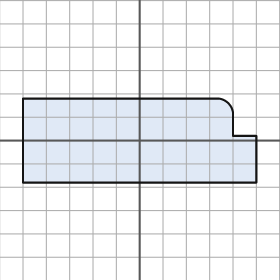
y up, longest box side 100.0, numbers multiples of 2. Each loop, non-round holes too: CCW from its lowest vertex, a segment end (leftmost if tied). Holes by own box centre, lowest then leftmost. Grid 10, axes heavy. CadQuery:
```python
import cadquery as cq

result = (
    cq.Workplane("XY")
    .moveTo(-50.0, -18.0)
    .lineTo(50.0, -18.0)
    .lineTo(50.0, 2.0)
    .lineTo(40.0, 2.0)
    .lineTo(40.0, 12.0)
    .threePointArc((38.0, 16.0), (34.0, 18.0))
    .lineTo(-50.0, 18.0)
    .close()
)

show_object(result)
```